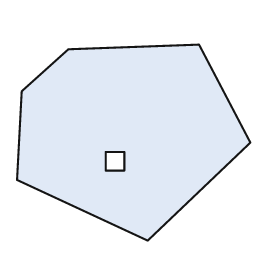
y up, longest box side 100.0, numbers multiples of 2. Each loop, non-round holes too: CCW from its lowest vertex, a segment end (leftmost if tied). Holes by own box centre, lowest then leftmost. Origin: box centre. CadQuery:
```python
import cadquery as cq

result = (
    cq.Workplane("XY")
    .moveTo(6.0, -42.0)
    .lineTo(50.0, 0.0)
    .lineTo(28.0, 42.0)
    .lineTo(-28.0, 40.0)
    .lineTo(-48.0, 22.0)
    .lineTo(-50.0, -16.0)
    .close()
    .moveTo(-12.0, -12.0)
    .lineTo(-4.0, -12.0)
    .lineTo(-4.0, -4.0)
    .lineTo(-12.0, -4.0)
    .close()
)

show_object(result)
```